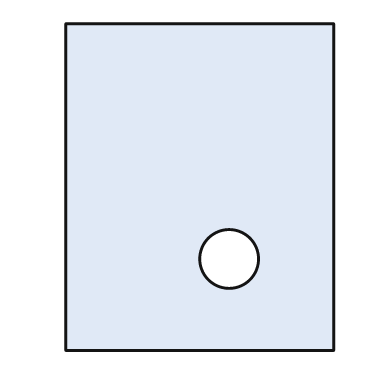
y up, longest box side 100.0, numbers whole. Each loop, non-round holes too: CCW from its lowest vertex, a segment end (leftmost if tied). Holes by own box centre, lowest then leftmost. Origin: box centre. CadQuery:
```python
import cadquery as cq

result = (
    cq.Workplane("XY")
    .moveTo(-41.0, -50.0)
    .lineTo(41.0, -50.0)
    .lineTo(41.0, 50.0)
    .lineTo(-41.0, 50.0)
    .close()
    .moveTo(9.0, -22.0)
    .circle(9.0)
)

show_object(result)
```